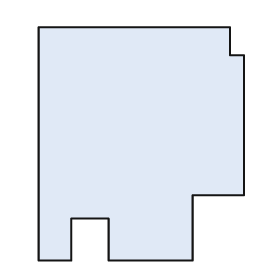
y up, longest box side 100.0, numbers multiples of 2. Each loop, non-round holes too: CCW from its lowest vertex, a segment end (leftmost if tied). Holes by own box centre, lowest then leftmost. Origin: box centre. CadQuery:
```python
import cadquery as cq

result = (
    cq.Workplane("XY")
    .moveTo(-44.0, -50.0)
    .lineTo(-30.0, -50.0)
    .lineTo(-30.0, -32.0)
    .lineTo(-14.0, -32.0)
    .lineTo(-14.0, -50.0)
    .lineTo(22.0, -50.0)
    .lineTo(22.0, -22.0)
    .lineTo(44.0, -22.0)
    .lineTo(44.0, 38.0)
    .lineTo(38.0, 38.0)
    .lineTo(38.0, 50.0)
    .lineTo(-44.0, 50.0)
    .close()
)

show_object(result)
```